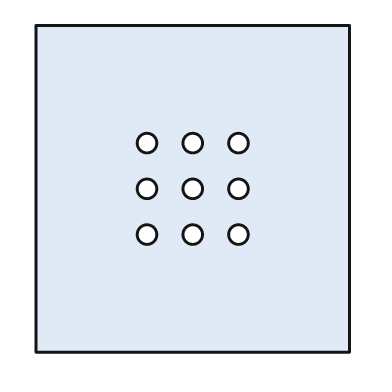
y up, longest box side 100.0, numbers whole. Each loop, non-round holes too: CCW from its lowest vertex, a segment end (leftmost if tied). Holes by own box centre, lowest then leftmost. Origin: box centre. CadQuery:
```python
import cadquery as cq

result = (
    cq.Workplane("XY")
    .moveTo(-48.0, -50.0)
    .lineTo(48.0, -50.0)
    .lineTo(48.0, 50.0)
    .lineTo(-48.0, 50.0)
    .close()
    .moveTo(-14.0, -14.0)
    .circle(3.0)
    .moveTo(0.0, -14.0)
    .circle(3.0)
    .moveTo(14.0, -14.0)
    .circle(3.0)
    .moveTo(-14.0, 0.0)
    .circle(3.0)
    .moveTo(0.0, 0.0)
    .circle(3.0)
    .moveTo(14.0, 0.0)
    .circle(3.0)
    .moveTo(-14.0, 14.0)
    .circle(3.0)
    .moveTo(0.0, 14.0)
    .circle(3.0)
    .moveTo(14.0, 14.0)
    .circle(3.0)
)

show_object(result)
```